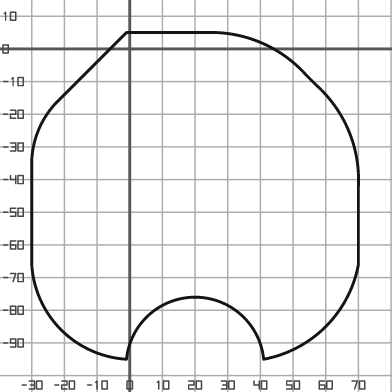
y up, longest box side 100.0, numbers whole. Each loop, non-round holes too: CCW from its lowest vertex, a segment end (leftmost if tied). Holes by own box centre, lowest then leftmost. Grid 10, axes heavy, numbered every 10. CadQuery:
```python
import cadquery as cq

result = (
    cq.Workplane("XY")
    .moveTo(-1.0, -95.0)
    .threePointArc((20.0, -76.0), (41.0, -95.0))
    .threePointArc((60.0, -85.0), (70.0, -66.0))
    .lineTo(70.0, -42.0)
    .threePointArc((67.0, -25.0), (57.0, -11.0))
    .lineTo(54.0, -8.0)
    .threePointArc((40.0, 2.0), (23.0, 5.0))
    .lineTo(-1.0, 5.0)
    .lineTo(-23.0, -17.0)
    .threePointArc((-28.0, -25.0), (-30.0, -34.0))
    .lineTo(-30.0, -66.0)
    .threePointArc((-21.0, -86.0), (-1.0, -95.0))
    .close()
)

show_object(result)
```